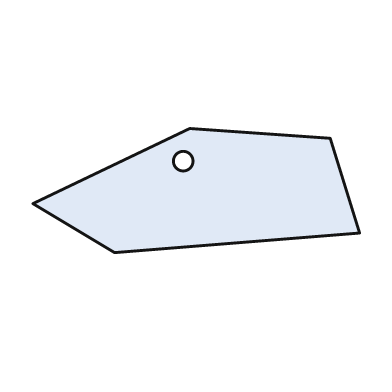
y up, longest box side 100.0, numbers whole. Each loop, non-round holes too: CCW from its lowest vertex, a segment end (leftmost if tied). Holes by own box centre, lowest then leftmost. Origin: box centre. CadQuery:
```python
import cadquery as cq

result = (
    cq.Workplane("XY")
    .moveTo(-25.0, -19.0)
    .lineTo(50.0, -13.0)
    .lineTo(41.0, 16.0)
    .lineTo(-2.0, 19.0)
    .lineTo(-50.0, -4.0)
    .close()
    .moveTo(-4.0, 9.0)
    .circle(3.0)
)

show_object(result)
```